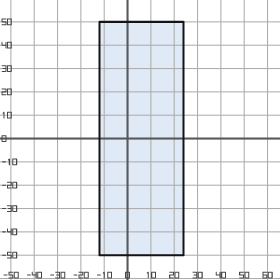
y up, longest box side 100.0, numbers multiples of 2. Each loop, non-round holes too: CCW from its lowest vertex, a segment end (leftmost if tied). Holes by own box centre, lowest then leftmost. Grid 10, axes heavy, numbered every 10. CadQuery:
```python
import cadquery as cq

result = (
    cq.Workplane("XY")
    .moveTo(-12.0, -50.0)
    .lineTo(24.0, -50.0)
    .lineTo(24.0, 50.0)
    .lineTo(-12.0, 50.0)
    .close()
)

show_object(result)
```